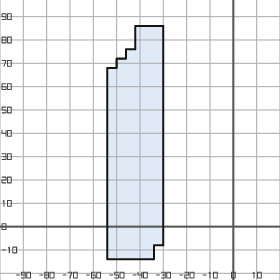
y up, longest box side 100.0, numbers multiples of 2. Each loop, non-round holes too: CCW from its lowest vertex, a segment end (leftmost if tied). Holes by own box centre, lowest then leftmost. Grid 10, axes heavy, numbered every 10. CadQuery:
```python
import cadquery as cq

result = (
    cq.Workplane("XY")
    .moveTo(-54.0, -14.0)
    .lineTo(-34.0, -14.0)
    .lineTo(-34.0, -8.0)
    .lineTo(-30.0, -8.0)
    .lineTo(-30.0, 86.0)
    .lineTo(-42.0, 86.0)
    .lineTo(-42.0, 76.0)
    .lineTo(-46.0, 76.0)
    .lineTo(-46.0, 72.0)
    .lineTo(-50.0, 72.0)
    .lineTo(-50.0, 68.0)
    .lineTo(-54.0, 68.0)
    .close()
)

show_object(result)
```